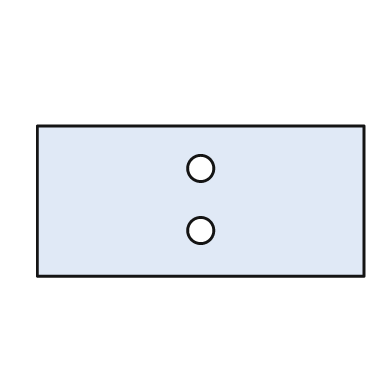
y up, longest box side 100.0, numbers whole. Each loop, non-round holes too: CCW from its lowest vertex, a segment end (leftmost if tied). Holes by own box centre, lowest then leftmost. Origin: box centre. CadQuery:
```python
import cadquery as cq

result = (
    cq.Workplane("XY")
    .moveTo(-50.0, -23.0)
    .lineTo(50.0, -23.0)
    .lineTo(50.0, 23.0)
    .lineTo(-50.0, 23.0)
    .close()
    .moveTo(0.0, -9.0)
    .circle(4.0)
    .moveTo(0.0, 10.0)
    .circle(4.0)
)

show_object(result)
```